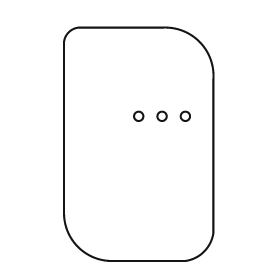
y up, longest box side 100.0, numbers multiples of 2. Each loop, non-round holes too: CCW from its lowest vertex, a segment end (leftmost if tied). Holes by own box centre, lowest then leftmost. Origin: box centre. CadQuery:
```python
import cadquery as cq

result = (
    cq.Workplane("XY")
    .moveTo(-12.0, -50.0)
    .lineTo(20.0, -50.0)
    .threePointArc((28.0, -46.0), (32.0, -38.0))
    .lineTo(32.0, 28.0)
    .threePointArc((26.0, 44.0), (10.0, 50.0))
    .lineTo(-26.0, 50.0)
    .threePointArc((-30.0, 48.0), (-32.0, 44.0))
    .lineTo(-32.0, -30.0)
    .threePointArc((-26.0, -44.0), (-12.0, -50.0))
    .close()
    .moveTo(0.0, 12.0)
    .circle(2.0)
    .moveTo(10.0, 12.0)
    .circle(2.0)
    .moveTo(20.0, 12.0)
    .circle(2.0)
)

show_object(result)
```